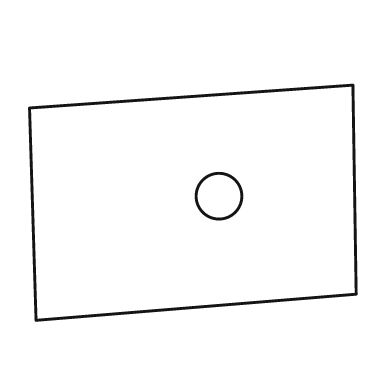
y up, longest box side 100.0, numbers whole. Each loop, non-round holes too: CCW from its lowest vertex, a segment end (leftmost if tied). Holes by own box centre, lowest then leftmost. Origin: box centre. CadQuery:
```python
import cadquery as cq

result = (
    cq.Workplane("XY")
    .moveTo(-48.0, -36.0)
    .lineTo(50.0, -28.0)
    .lineTo(49.0, 36.0)
    .lineTo(-50.0, 29.0)
    .close()
    .moveTo(8.0, 2.0)
    .circle(7.0)
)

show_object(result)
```